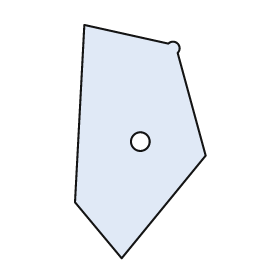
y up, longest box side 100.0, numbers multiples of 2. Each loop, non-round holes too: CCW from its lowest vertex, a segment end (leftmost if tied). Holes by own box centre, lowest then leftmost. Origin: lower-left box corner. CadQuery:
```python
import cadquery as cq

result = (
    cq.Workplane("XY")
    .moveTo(20.0, 0.0)
    .lineTo(56.0, 44.0)
    .lineTo(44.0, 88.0)
    .threePointArc((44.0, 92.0), (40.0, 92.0))
    .lineTo(4.0, 100.0)
    .lineTo(0.0, 24.0)
    .close()
    .moveTo(28.0, 50.0)
    .circle(4.0)
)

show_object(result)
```